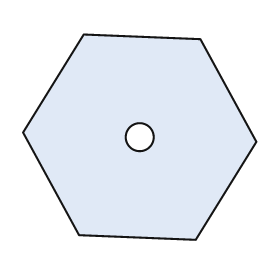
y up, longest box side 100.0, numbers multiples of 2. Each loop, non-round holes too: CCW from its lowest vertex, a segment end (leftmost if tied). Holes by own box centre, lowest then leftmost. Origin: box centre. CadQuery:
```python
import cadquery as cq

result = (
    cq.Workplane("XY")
    .moveTo(24.0, -44.0)
    .lineTo(50.0, -2.0)
    .lineTo(26.0, 42.0)
    .lineTo(-24.0, 44.0)
    .lineTo(-50.0, 2.0)
    .lineTo(-26.0, -42.0)
    .close()
    .moveTo(0.0, 0.0)
    .circle(6.0)
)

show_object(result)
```